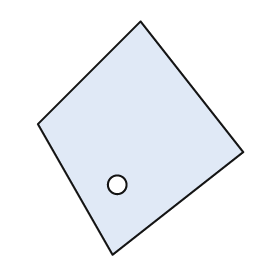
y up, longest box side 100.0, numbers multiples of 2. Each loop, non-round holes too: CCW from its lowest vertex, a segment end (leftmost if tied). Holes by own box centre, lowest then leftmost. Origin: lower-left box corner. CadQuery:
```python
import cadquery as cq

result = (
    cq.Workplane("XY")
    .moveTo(32.0, 0.0)
    .lineTo(88.0, 44.0)
    .lineTo(44.0, 100.0)
    .lineTo(0.0, 56.0)
    .close()
    .moveTo(34.0, 30.0)
    .circle(4.0)
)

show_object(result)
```